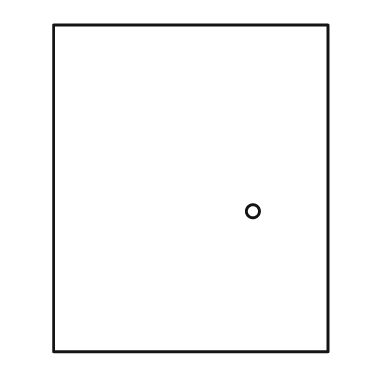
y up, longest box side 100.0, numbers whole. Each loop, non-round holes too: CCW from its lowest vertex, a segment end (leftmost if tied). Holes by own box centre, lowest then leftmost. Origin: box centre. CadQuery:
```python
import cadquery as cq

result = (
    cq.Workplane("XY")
    .moveTo(-42.0, -50.0)
    .lineTo(42.0, -50.0)
    .lineTo(42.0, 50.0)
    .lineTo(-42.0, 50.0)
    .close()
    .moveTo(19.0, -7.0)
    .circle(2.0)
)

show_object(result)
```